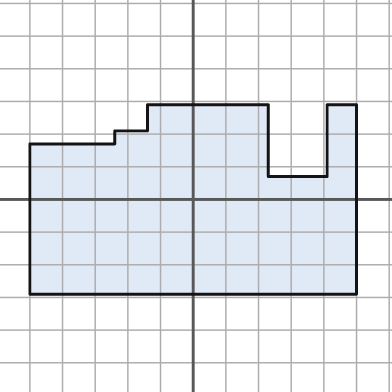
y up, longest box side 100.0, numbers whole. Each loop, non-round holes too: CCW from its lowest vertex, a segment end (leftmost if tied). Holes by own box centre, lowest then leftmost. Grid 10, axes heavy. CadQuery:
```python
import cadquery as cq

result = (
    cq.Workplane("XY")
    .moveTo(-50.0, -29.0)
    .lineTo(50.0, -29.0)
    .lineTo(50.0, 29.0)
    .lineTo(41.0, 29.0)
    .lineTo(41.0, 7.0)
    .lineTo(23.0, 7.0)
    .lineTo(23.0, 29.0)
    .lineTo(-14.0, 29.0)
    .lineTo(-14.0, 21.0)
    .lineTo(-24.0, 21.0)
    .lineTo(-24.0, 17.0)
    .lineTo(-50.0, 17.0)
    .close()
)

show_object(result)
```